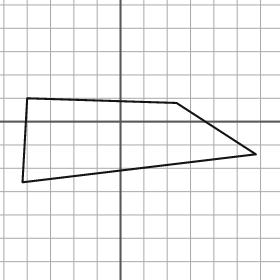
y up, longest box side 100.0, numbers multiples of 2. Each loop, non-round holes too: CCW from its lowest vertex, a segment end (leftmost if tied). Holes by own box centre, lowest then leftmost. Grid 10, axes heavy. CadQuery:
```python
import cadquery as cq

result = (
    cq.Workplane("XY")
    .moveTo(-42.0, -26.0)
    .lineTo(58.0, -14.0)
    .lineTo(24.0, 8.0)
    .lineTo(-40.0, 10.0)
    .close()
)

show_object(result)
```